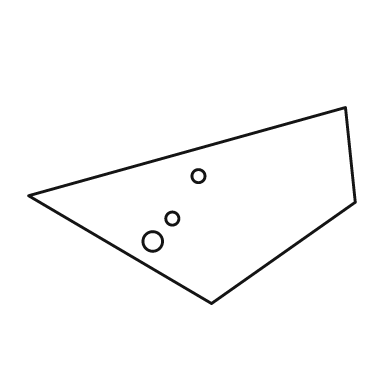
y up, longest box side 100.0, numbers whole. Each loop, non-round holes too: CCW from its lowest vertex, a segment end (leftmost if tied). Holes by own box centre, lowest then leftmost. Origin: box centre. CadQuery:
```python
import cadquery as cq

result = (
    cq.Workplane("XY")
    .moveTo(6.0, -30.0)
    .lineTo(50.0, 1.0)
    .lineTo(47.0, 30.0)
    .lineTo(-50.0, 3.0)
    .close()
    .moveTo(-12.0, -11.0)
    .circle(3.0)
    .moveTo(-6.0, -4.0)
    .circle(2.0)
    .moveTo(2.0, 9.0)
    .circle(2.0)
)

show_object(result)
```